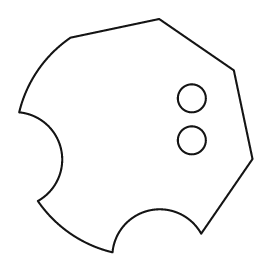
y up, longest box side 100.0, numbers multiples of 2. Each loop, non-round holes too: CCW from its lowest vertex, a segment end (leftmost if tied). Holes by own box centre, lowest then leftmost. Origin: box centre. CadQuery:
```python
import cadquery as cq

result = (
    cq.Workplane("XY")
    .moveTo(-10.0, -50.0)
    .threePointArc((6.0, -32.0), (28.0, -42.0))
    .lineTo(50.0, -10.0)
    .lineTo(42.0, 28.0)
    .lineTo(10.0, 50.0)
    .lineTo(-28.0, 42.0)
    .threePointArc((-42.0, 28.0), (-50.0, 10.0))
    .threePointArc((-32.0, -6.0), (-42.0, -28.0))
    .threePointArc((-28.0, -42.0), (-10.0, -50.0))
    .close()
    .moveTo(24.0, -2.0)
    .circle(6.0)
    .moveTo(24.0, 16.0)
    .circle(6.0)
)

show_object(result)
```